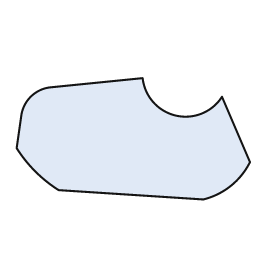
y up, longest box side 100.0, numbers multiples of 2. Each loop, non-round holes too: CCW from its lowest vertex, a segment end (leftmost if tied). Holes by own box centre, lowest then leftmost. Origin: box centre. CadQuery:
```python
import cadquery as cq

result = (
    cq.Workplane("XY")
    .moveTo(30.0, -26.0)
    .threePointArc((42.0, -20.0), (50.0, -10.0))
    .lineTo(38.0, 18.0)
    .threePointArc((18.0, 10.0), (4.0, 26.0))
    .lineTo(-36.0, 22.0)
    .threePointArc((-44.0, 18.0), (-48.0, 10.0))
    .lineTo(-50.0, -4.0)
    .threePointArc((-42.0, -14.0), (-32.0, -22.0))
    .close()
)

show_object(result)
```